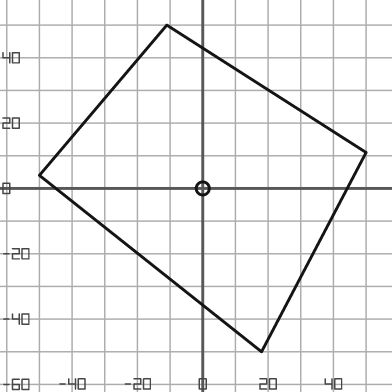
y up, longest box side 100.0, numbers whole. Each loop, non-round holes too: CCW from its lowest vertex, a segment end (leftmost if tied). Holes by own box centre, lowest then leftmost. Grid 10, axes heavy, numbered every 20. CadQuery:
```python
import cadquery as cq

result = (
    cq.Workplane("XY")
    .moveTo(18.0, -50.0)
    .lineTo(50.0, 11.0)
    .lineTo(-11.0, 50.0)
    .lineTo(-50.0, 4.0)
    .close()
    .moveTo(0.0, 0.0)
    .circle(2.0)
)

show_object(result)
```